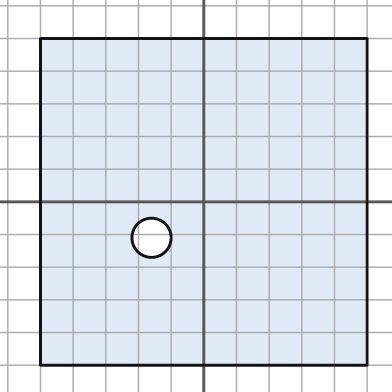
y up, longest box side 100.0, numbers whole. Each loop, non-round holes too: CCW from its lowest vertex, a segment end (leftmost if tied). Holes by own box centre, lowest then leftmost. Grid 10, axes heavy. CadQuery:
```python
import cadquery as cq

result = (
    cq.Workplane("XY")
    .moveTo(-50.0, -50.0)
    .lineTo(50.0, -50.0)
    .lineTo(50.0, 50.0)
    .lineTo(-50.0, 50.0)
    .close()
    .moveTo(-16.0, -11.0)
    .circle(6.0)
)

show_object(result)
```